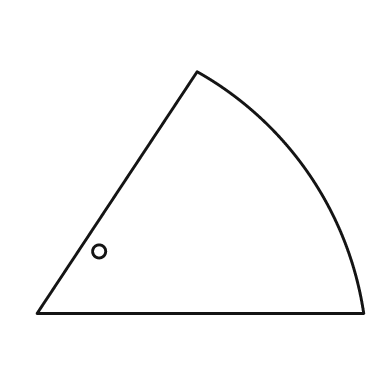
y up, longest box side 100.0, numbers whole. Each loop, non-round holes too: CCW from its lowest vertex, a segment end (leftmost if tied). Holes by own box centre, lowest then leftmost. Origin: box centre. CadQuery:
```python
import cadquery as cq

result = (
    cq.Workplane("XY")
    .moveTo(-50.0, -37.0)
    .lineTo(50.0, -37.0)
    .threePointArc((33.0, 6.0), (-1.0, 37.0))
    .close()
    .moveTo(-31.0, -18.0)
    .circle(2.0)
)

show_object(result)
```